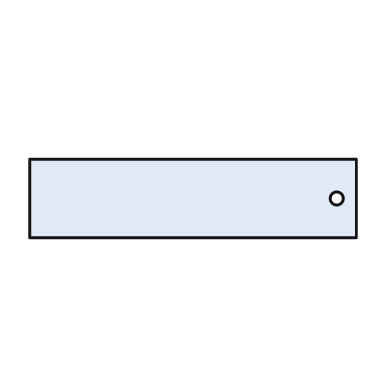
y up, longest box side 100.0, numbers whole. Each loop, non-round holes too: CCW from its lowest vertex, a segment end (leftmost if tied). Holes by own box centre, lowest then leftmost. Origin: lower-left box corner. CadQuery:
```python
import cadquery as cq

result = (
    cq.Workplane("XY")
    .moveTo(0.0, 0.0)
    .lineTo(100.0, 0.0)
    .lineTo(100.0, 24.0)
    .lineTo(0.0, 24.0)
    .close()
    .moveTo(94.0, 12.0)
    .circle(2.0)
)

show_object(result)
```